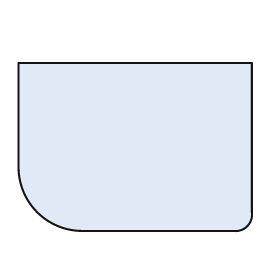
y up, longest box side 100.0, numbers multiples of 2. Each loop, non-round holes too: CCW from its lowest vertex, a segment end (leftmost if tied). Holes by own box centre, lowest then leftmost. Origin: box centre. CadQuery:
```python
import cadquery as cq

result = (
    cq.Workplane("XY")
    .moveTo(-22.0, -36.0)
    .lineTo(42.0, -36.0)
    .threePointArc((48.0, -34.0), (50.0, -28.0))
    .lineTo(50.0, 36.0)
    .lineTo(-50.0, 36.0)
    .lineTo(-50.0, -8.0)
    .threePointArc((-42.0, -28.0), (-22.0, -36.0))
    .close()
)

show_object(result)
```